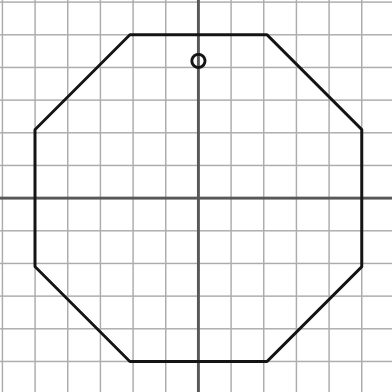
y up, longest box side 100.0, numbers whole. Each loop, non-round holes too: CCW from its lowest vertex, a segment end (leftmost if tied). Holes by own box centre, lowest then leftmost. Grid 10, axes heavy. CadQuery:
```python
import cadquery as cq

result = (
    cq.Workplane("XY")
    .moveTo(-21.0, -50.0)
    .lineTo(21.0, -50.0)
    .lineTo(50.0, -21.0)
    .lineTo(50.0, 21.0)
    .lineTo(21.0, 50.0)
    .lineTo(-21.0, 50.0)
    .lineTo(-50.0, 21.0)
    .lineTo(-50.0, -21.0)
    .close()
    .moveTo(0.0, 42.0)
    .circle(2.0)
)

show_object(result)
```